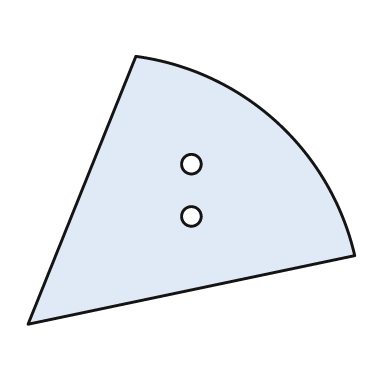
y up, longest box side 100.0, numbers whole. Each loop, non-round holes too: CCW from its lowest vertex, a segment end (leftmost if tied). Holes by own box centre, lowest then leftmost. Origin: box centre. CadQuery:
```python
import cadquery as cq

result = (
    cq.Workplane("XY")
    .moveTo(-50.0, -41.0)
    .lineTo(50.0, -20.0)
    .threePointArc((26.0, 21.0), (-17.0, 41.0))
    .close()
    .moveTo(0.0, -8.0)
    .circle(3.0)
    .moveTo(0.0, 8.0)
    .circle(3.0)
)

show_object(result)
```